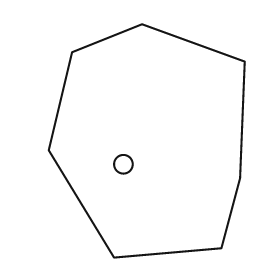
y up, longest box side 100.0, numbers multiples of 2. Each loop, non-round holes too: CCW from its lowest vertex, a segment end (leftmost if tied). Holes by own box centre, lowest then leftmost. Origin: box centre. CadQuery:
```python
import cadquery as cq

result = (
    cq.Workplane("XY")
    .moveTo(-14.0, -50.0)
    .lineTo(32.0, -46.0)
    .lineTo(40.0, -16.0)
    .lineTo(42.0, 34.0)
    .lineTo(-2.0, 50.0)
    .lineTo(-32.0, 38.0)
    .lineTo(-42.0, -4.0)
    .close()
    .moveTo(-10.0, -10.0)
    .circle(4.0)
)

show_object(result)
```